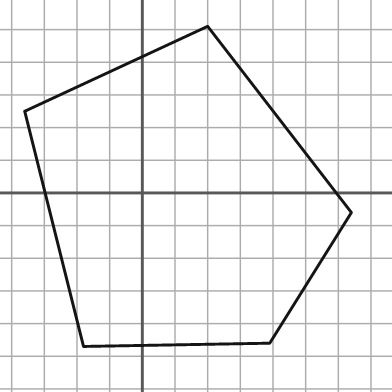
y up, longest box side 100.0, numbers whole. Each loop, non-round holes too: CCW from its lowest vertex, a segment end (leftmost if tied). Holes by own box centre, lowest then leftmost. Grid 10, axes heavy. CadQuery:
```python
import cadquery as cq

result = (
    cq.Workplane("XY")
    .moveTo(-18.0, -47.0)
    .lineTo(39.0, -46.0)
    .lineTo(64.0, -6.0)
    .lineTo(20.0, 51.0)
    .lineTo(-36.0, 25.0)
    .close()
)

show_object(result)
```